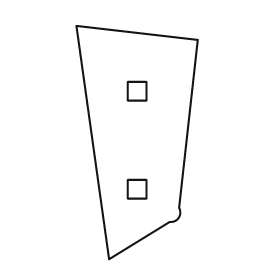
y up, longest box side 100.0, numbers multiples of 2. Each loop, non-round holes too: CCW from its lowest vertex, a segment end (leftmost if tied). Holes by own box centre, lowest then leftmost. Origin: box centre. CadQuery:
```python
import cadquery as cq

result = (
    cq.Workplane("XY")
    .moveTo(-12.0, -50.0)
    .lineTo(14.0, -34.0)
    .threePointArc((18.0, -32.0), (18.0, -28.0))
    .lineTo(26.0, 44.0)
    .lineTo(-26.0, 50.0)
    .close()
    .moveTo(-4.0, -24.0)
    .lineTo(4.0, -24.0)
    .lineTo(4.0, -16.0)
    .lineTo(-4.0, -16.0)
    .close()
    .moveTo(-4.0, 18.0)
    .lineTo(4.0, 18.0)
    .lineTo(4.0, 26.0)
    .lineTo(-4.0, 26.0)
    .close()
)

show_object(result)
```